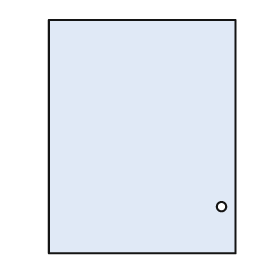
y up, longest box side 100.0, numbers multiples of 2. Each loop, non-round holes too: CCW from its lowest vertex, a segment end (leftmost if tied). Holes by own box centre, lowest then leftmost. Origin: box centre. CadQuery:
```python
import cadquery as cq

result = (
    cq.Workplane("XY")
    .moveTo(-40.0, -50.0)
    .lineTo(40.0, -50.0)
    .lineTo(40.0, 50.0)
    .lineTo(-40.0, 50.0)
    .close()
    .moveTo(34.0, -30.0)
    .circle(2.0)
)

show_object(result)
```